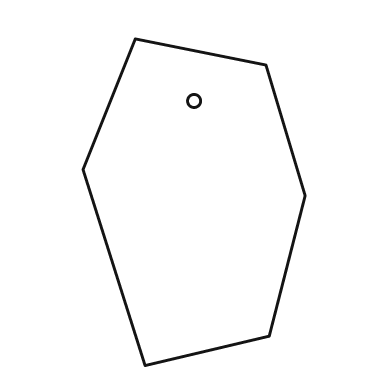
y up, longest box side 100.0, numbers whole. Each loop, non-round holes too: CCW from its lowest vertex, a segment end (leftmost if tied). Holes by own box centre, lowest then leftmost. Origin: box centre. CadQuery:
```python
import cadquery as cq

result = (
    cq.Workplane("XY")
    .moveTo(-15.0, -50.0)
    .lineTo(23.0, -41.0)
    .lineTo(34.0, 2.0)
    .lineTo(22.0, 42.0)
    .lineTo(-18.0, 50.0)
    .lineTo(-34.0, 10.0)
    .close()
    .moveTo(0.0, 31.0)
    .circle(2.0)
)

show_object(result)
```